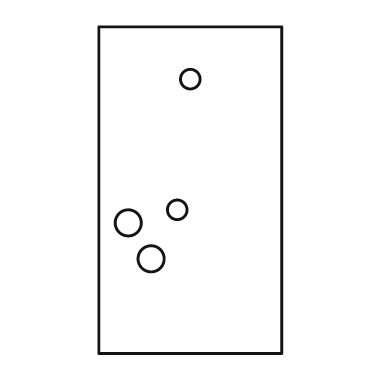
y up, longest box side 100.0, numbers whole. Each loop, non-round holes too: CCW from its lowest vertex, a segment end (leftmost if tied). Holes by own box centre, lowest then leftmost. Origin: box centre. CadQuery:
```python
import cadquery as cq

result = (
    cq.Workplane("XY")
    .moveTo(-28.0, -50.0)
    .lineTo(28.0, -50.0)
    .lineTo(28.0, 50.0)
    .lineTo(-28.0, 50.0)
    .close()
    .moveTo(-12.0, -21.0)
    .circle(4.0)
    .moveTo(-19.0, -10.0)
    .circle(4.0)
    .moveTo(-4.0, -6.0)
    .circle(3.0)
    .moveTo(0.0, 34.0)
    .circle(3.0)
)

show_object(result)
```